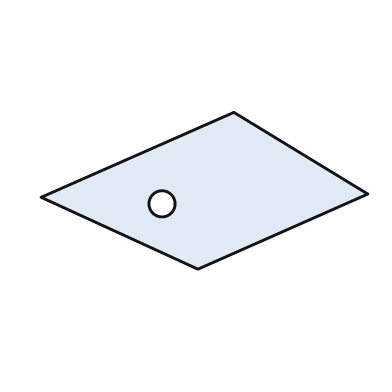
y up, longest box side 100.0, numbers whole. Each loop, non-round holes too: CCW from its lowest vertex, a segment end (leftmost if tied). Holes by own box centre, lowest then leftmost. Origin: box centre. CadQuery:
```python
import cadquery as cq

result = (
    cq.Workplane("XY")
    .moveTo(-2.0, -24.0)
    .lineTo(50.0, -1.0)
    .lineTo(9.0, 24.0)
    .lineTo(-50.0, -2.0)
    .close()
    .moveTo(-13.0, -4.0)
    .circle(4.0)
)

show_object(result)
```